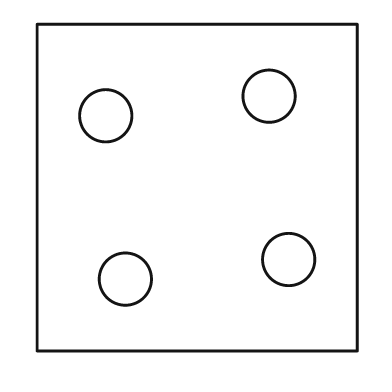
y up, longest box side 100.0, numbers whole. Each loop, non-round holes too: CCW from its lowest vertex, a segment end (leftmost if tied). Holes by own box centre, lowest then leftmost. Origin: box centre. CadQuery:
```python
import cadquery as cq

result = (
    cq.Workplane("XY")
    .moveTo(-49.0, -50.0)
    .lineTo(49.0, -50.0)
    .lineTo(49.0, 50.0)
    .lineTo(-49.0, 50.0)
    .close()
    .moveTo(-22.0, -28.0)
    .circle(8.0)
    .moveTo(28.0, -22.0)
    .circle(8.0)
    .moveTo(-28.0, 22.0)
    .circle(8.0)
    .moveTo(22.0, 28.0)
    .circle(8.0)
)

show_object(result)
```